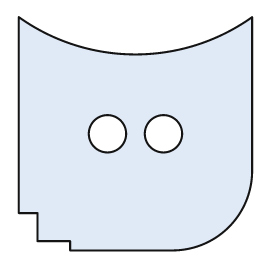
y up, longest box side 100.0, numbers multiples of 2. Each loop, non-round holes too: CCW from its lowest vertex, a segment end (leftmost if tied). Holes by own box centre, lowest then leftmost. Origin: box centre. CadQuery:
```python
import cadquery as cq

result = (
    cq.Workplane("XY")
    .moveTo(-28.0, -50.0)
    .lineTo(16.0, -50.0)
    .threePointArc((40.0, -40.0), (50.0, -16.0))
    .lineTo(50.0, 50.0)
    .threePointArc((0.0, 34.0), (-50.0, 50.0))
    .lineTo(-50.0, -34.0)
    .lineTo(-42.0, -34.0)
    .lineTo(-42.0, -46.0)
    .lineTo(-28.0, -46.0)
    .close()
    .moveTo(-12.0, 0.0)
    .circle(8.0)
    .moveTo(12.0, 0.0)
    .circle(8.0)
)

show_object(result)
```